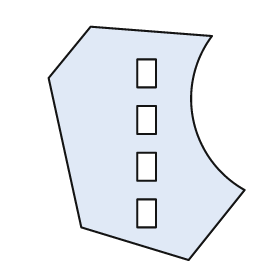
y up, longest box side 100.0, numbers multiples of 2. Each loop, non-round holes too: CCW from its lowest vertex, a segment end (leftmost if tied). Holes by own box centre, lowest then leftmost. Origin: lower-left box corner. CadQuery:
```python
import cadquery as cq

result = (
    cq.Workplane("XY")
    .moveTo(60.0, 0.0)
    .lineTo(84.0, 30.0)
    .threePointArc((62.0, 60.0), (70.0, 96.0))
    .lineTo(18.0, 100.0)
    .lineTo(0.0, 78.0)
    .lineTo(14.0, 14.0)
    .close()
    .moveTo(38.0, 14.0)
    .lineTo(46.0, 14.0)
    .lineTo(46.0, 26.0)
    .lineTo(38.0, 26.0)
    .close()
    .moveTo(38.0, 34.0)
    .lineTo(46.0, 34.0)
    .lineTo(46.0, 46.0)
    .lineTo(38.0, 46.0)
    .close()
    .moveTo(38.0, 54.0)
    .lineTo(46.0, 54.0)
    .lineTo(46.0, 66.0)
    .lineTo(38.0, 66.0)
    .close()
    .moveTo(38.0, 74.0)
    .lineTo(46.0, 74.0)
    .lineTo(46.0, 86.0)
    .lineTo(38.0, 86.0)
    .close()
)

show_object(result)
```